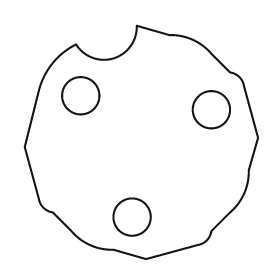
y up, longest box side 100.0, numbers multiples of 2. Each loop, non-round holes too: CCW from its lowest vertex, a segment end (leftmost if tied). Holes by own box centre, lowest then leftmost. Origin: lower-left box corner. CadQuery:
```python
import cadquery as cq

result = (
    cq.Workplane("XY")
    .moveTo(52.0, 0.0)
    .lineTo(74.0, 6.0)
    .threePointArc((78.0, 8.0), (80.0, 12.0))
    .lineTo(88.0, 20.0)
    .threePointArc((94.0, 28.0), (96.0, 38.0))
    .lineTo(100.0, 52.0)
    .lineTo(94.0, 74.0)
    .threePointArc((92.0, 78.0), (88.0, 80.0))
    .lineTo(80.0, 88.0)
    .threePointArc((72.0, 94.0), (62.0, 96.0))
    .lineTo(48.0, 100.0)
    .threePointArc((38.0, 86.0), (22.0, 92.0))
    .threePointArc((12.0, 84.0), (6.0, 72.0))
    .lineTo(0.0, 48.0)
    .lineTo(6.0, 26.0)
    .threePointArc((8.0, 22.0), (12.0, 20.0))
    .lineTo(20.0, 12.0)
    .threePointArc((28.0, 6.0), (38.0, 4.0))
    .close()
    .moveTo(46.0, 18.0)
    .circle(8.0)
    .moveTo(80.0, 64.0)
    .circle(8.0)
    .moveTo(24.0, 70.0)
    .circle(8.0)
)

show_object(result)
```